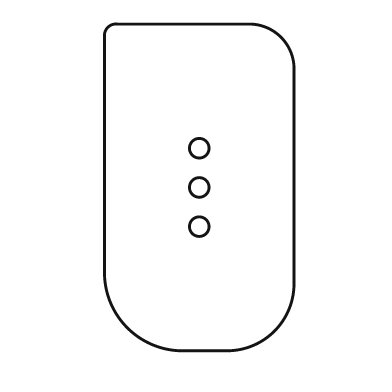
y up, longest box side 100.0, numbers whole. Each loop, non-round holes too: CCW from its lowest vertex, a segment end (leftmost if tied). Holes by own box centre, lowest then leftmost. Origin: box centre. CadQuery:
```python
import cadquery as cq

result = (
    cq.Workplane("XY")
    .moveTo(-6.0, -50.0)
    .lineTo(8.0, -50.0)
    .threePointArc((23.0, -44.0), (29.0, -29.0))
    .lineTo(29.0, 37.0)
    .threePointArc((25.0, 46.0), (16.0, 50.0))
    .lineTo(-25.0, 50.0)
    .threePointArc((-28.0, 49.0), (-29.0, 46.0))
    .lineTo(-29.0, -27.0)
    .threePointArc((-22.0, -43.0), (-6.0, -50.0))
    .close()
    .moveTo(0.0, -12.0)
    .circle(3.0)
    .moveTo(0.0, 0.0)
    .circle(3.0)
    .moveTo(0.0, 12.0)
    .circle(3.0)
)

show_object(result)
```